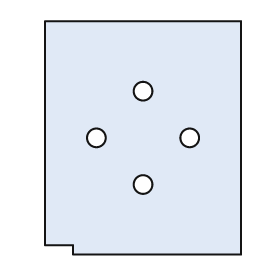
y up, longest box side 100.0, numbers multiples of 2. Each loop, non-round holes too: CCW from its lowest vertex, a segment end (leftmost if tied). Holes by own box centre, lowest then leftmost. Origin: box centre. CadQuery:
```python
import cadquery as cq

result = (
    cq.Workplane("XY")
    .moveTo(-30.0, -50.0)
    .lineTo(42.0, -50.0)
    .lineTo(42.0, 50.0)
    .lineTo(-42.0, 50.0)
    .lineTo(-42.0, -46.0)
    .lineTo(-30.0, -46.0)
    .close()
    .moveTo(0.0, -20.0)
    .circle(4.0)
    .moveTo(-20.0, 0.0)
    .circle(4.0)
    .moveTo(20.0, 0.0)
    .circle(4.0)
    .moveTo(0.0, 20.0)
    .circle(4.0)
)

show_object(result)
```